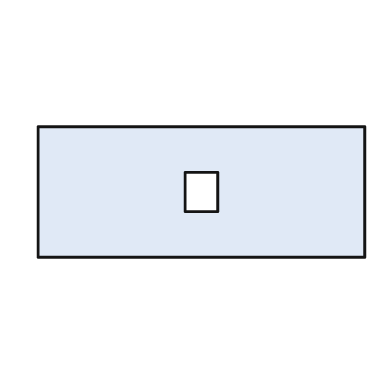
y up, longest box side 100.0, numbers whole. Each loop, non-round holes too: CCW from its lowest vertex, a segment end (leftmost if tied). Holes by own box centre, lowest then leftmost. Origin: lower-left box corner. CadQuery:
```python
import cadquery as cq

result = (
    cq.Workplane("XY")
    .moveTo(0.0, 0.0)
    .lineTo(100.0, 0.0)
    .lineTo(100.0, 40.0)
    .lineTo(0.0, 40.0)
    .close()
    .moveTo(45.0, 14.0)
    .lineTo(55.0, 14.0)
    .lineTo(55.0, 26.0)
    .lineTo(45.0, 26.0)
    .close()
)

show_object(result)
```